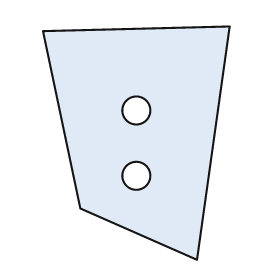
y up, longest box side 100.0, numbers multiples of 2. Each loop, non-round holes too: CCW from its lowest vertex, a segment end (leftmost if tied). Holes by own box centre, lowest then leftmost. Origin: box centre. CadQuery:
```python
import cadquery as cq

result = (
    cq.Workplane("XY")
    .moveTo(26.0, -50.0)
    .lineTo(40.0, 50.0)
    .lineTo(-40.0, 48.0)
    .lineTo(-24.0, -28.0)
    .close()
    .moveTo(0.0, -14.0)
    .circle(6.0)
    .moveTo(0.0, 14.0)
    .circle(6.0)
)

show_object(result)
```